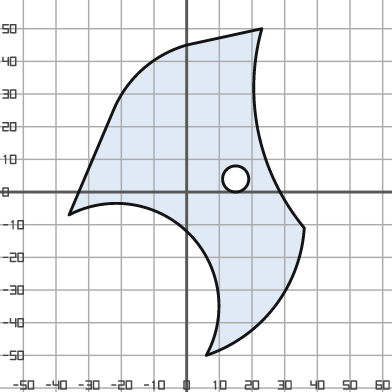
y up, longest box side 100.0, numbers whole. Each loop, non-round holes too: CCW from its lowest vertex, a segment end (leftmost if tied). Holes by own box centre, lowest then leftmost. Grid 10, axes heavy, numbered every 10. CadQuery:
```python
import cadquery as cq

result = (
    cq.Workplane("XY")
    .moveTo(6.0, -50.0)
    .threePointArc((27.0, -35.0), (36.0, -11.0))
    .threePointArc((22.0, 18.0), (23.0, 50.0))
    .lineTo(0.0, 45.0)
    .threePointArc((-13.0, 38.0), (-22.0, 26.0))
    .lineTo(-36.0, -7.0)
    .threePointArc((1.0, -13.0), (6.0, -50.0))
    .close()
    .moveTo(15.0, 4.0)
    .circle(4.0)
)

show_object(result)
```